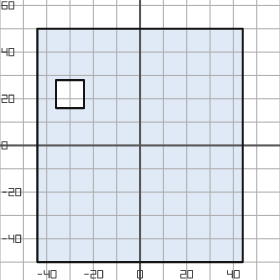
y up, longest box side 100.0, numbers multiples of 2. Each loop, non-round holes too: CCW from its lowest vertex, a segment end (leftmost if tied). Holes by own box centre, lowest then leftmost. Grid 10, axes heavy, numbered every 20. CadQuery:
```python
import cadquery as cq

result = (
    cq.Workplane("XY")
    .moveTo(-44.0, -50.0)
    .lineTo(44.0, -50.0)
    .lineTo(44.0, 50.0)
    .lineTo(-44.0, 50.0)
    .close()
    .moveTo(-36.0, 16.0)
    .lineTo(-24.0, 16.0)
    .lineTo(-24.0, 28.0)
    .lineTo(-36.0, 28.0)
    .close()
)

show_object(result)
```